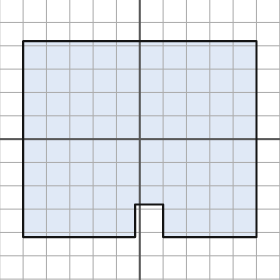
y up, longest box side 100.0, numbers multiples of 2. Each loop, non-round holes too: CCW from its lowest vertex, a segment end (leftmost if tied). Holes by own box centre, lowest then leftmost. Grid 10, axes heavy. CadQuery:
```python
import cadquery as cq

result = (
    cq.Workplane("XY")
    .moveTo(-50.0, -42.0)
    .lineTo(-2.0, -42.0)
    .lineTo(-2.0, -28.0)
    .lineTo(10.0, -28.0)
    .lineTo(10.0, -42.0)
    .lineTo(50.0, -42.0)
    .lineTo(50.0, 42.0)
    .lineTo(-50.0, 42.0)
    .close()
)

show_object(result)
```